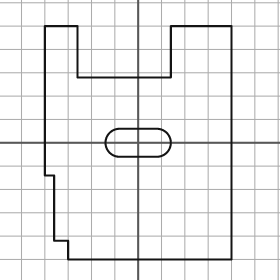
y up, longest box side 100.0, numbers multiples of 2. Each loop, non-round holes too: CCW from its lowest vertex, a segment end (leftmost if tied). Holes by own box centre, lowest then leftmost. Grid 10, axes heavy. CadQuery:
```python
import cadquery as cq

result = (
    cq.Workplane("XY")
    .moveTo(-30.0, -50.0)
    .lineTo(40.0, -50.0)
    .lineTo(40.0, 50.0)
    .lineTo(14.0, 50.0)
    .lineTo(14.0, 28.0)
    .lineTo(-26.0, 28.0)
    .lineTo(-26.0, 50.0)
    .lineTo(-40.0, 50.0)
    .lineTo(-40.0, -14.0)
    .lineTo(-36.0, -14.0)
    .lineTo(-36.0, -42.0)
    .lineTo(-30.0, -42.0)
    .close()
    .moveTo(-8.0, -6.0)
    .lineTo(8.0, -6.0)
    .threePointArc((14.0, 0.0), (8.0, 6.0))
    .lineTo(-8.0, 6.0)
    .threePointArc((-14.0, 0.0), (-8.0, -6.0))
    .close()
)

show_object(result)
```